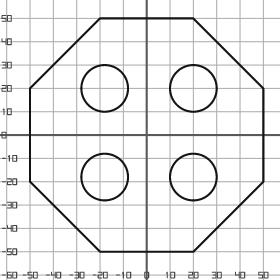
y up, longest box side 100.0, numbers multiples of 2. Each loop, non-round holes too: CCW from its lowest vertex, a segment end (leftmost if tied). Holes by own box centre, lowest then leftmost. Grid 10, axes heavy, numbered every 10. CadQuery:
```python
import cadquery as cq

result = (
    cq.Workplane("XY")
    .moveTo(-20.0, -50.0)
    .lineTo(20.0, -50.0)
    .lineTo(50.0, -20.0)
    .lineTo(50.0, 20.0)
    .lineTo(20.0, 50.0)
    .lineTo(-20.0, 50.0)
    .lineTo(-50.0, 20.0)
    .lineTo(-50.0, -20.0)
    .close()
    .moveTo(-18.0, -18.0)
    .circle(10.0)
    .moveTo(20.0, -18.0)
    .circle(10.0)
    .moveTo(-18.0, 20.0)
    .circle(10.0)
    .moveTo(20.0, 20.0)
    .circle(10.0)
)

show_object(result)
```